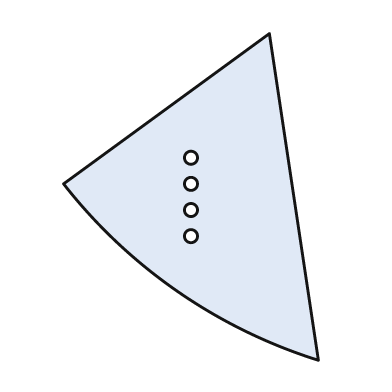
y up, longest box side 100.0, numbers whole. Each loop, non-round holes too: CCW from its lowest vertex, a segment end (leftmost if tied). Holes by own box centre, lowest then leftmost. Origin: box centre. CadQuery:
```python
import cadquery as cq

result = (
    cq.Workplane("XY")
    .moveTo(39.0, -50.0)
    .lineTo(24.0, 50.0)
    .lineTo(-39.0, 4.0)
    .threePointArc((-4.0, -29.0), (39.0, -50.0))
    .close()
    .moveTo(0.0, -12.0)
    .circle(2.0)
    .moveTo(0.0, -4.0)
    .circle(2.0)
    .moveTo(0.0, 4.0)
    .circle(2.0)
    .moveTo(0.0, 12.0)
    .circle(2.0)
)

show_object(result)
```